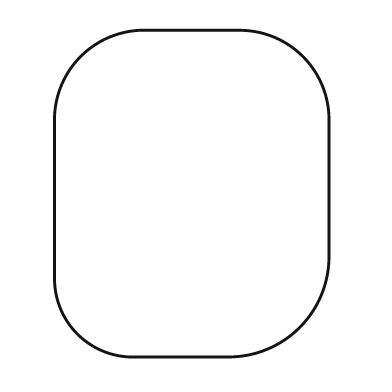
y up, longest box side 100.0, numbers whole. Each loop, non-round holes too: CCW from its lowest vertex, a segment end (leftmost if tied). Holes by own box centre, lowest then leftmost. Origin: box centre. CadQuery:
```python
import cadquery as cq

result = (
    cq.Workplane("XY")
    .moveTo(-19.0, -50.0)
    .lineTo(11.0, -50.0)
    .threePointArc((33.0, -41.0), (42.0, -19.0))
    .lineTo(42.0, 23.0)
    .threePointArc((34.0, 42.0), (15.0, 50.0))
    .lineTo(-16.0, 50.0)
    .threePointArc((-34.0, 42.0), (-42.0, 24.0))
    .lineTo(-42.0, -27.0)
    .threePointArc((-35.0, -43.0), (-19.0, -50.0))
    .close()
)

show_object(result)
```